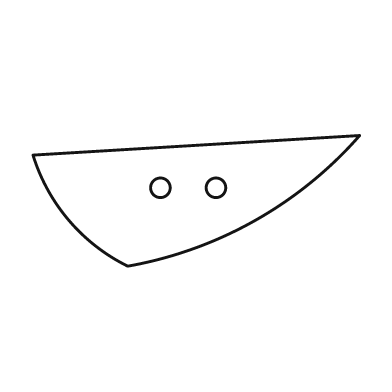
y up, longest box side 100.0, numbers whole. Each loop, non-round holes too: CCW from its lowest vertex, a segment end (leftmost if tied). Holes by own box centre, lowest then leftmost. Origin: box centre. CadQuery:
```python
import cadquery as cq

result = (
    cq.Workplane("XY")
    .moveTo(-21.0, -20.0)
    .threePointArc((18.0, -6.0), (50.0, 20.0))
    .lineTo(-50.0, 14.0)
    .threePointArc((-39.0, -6.0), (-21.0, -20.0))
    .close()
    .moveTo(-11.0, 4.0)
    .circle(3.0)
    .moveTo(6.0, 4.0)
    .circle(3.0)
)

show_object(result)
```